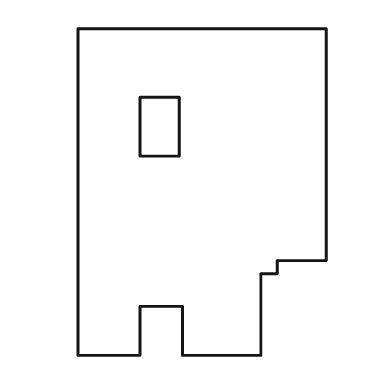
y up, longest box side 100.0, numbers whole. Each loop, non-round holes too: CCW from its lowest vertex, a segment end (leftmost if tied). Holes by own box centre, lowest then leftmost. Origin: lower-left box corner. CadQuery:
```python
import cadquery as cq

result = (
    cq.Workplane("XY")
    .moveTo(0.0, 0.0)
    .lineTo(19.0, 0.0)
    .lineTo(19.0, 15.0)
    .lineTo(32.0, 15.0)
    .lineTo(32.0, 0.0)
    .lineTo(56.0, 0.0)
    .lineTo(56.0, 25.0)
    .lineTo(61.0, 25.0)
    .lineTo(61.0, 29.0)
    .lineTo(76.0, 29.0)
    .lineTo(76.0, 100.0)
    .lineTo(0.0, 100.0)
    .close()
    .moveTo(19.0, 61.0)
    .lineTo(31.0, 61.0)
    .lineTo(31.0, 79.0)
    .lineTo(19.0, 79.0)
    .close()
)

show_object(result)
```